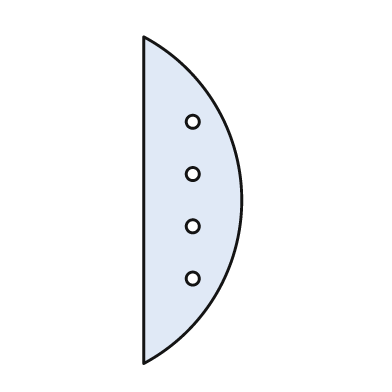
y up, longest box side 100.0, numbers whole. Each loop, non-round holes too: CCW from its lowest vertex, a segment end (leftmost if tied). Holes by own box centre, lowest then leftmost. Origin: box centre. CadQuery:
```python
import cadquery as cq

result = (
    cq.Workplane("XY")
    .moveTo(-15.0, -50.0)
    .threePointArc((15.0, 0.0), (-15.0, 50.0))
    .close()
    .moveTo(0.0, -24.0)
    .circle(2.0)
    .moveTo(0.0, -8.0)
    .circle(2.0)
    .moveTo(0.0, 8.0)
    .circle(2.0)
    .moveTo(0.0, 24.0)
    .circle(2.0)
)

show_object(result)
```